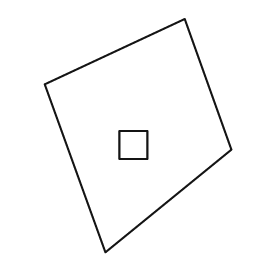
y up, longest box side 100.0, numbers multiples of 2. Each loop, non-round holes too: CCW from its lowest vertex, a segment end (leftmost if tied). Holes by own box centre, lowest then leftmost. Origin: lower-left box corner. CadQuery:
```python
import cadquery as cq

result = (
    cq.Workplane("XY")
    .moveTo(26.0, 0.0)
    .lineTo(80.0, 44.0)
    .lineTo(60.0, 100.0)
    .lineTo(0.0, 72.0)
    .close()
    .moveTo(32.0, 40.0)
    .lineTo(44.0, 40.0)
    .lineTo(44.0, 52.0)
    .lineTo(32.0, 52.0)
    .close()
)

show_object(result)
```